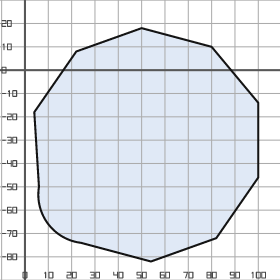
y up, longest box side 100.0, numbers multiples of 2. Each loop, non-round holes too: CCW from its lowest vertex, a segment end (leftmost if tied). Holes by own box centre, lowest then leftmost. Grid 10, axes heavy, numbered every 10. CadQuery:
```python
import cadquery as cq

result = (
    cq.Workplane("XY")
    .moveTo(54.0, -82.0)
    .lineTo(82.0, -72.0)
    .lineTo(100.0, -46.0)
    .lineTo(100.0, -14.0)
    .lineTo(80.0, 10.0)
    .lineTo(50.0, 18.0)
    .lineTo(22.0, 8.0)
    .lineTo(4.0, -18.0)
    .lineTo(6.0, -50.0)
    .threePointArc((10.0, -66.0), (24.0, -74.0))
    .close()
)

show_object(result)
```